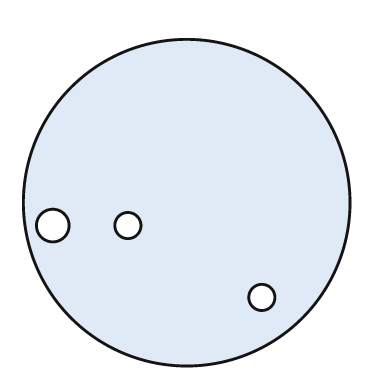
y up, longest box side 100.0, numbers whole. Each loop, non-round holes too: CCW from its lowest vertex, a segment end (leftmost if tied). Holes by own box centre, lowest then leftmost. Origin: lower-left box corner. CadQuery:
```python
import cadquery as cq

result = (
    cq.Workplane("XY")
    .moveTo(50.0, 50.0)
    .circle(50.0)
    .moveTo(73.0, 21.0)
    .circle(4.0)
    .moveTo(9.0, 43.0)
    .circle(5.0)
    .moveTo(32.0, 43.0)
    .circle(4.0)
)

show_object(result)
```